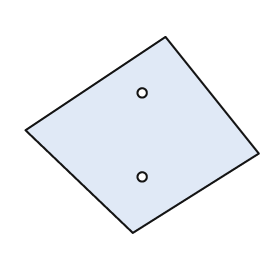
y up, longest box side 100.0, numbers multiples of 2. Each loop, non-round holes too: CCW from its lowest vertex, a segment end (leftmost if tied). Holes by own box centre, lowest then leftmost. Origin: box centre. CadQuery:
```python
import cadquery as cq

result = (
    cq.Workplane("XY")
    .moveTo(-4.0, -42.0)
    .lineTo(50.0, -8.0)
    .lineTo(10.0, 42.0)
    .lineTo(-50.0, 2.0)
    .close()
    .moveTo(0.0, -18.0)
    .circle(2.0)
    .moveTo(0.0, 18.0)
    .circle(2.0)
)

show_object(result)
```